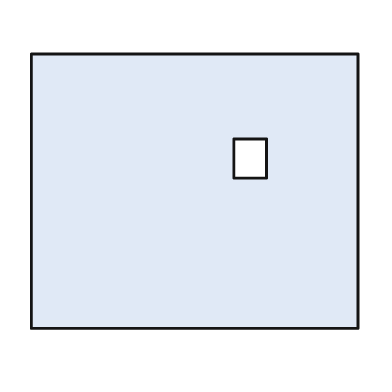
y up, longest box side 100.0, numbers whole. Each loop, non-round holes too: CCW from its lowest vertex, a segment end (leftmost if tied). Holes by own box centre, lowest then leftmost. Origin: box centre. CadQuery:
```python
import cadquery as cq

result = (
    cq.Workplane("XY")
    .moveTo(-50.0, -42.0)
    .lineTo(50.0, -42.0)
    .lineTo(50.0, 42.0)
    .lineTo(-50.0, 42.0)
    .close()
    .moveTo(12.0, 4.0)
    .lineTo(22.0, 4.0)
    .lineTo(22.0, 16.0)
    .lineTo(12.0, 16.0)
    .close()
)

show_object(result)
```